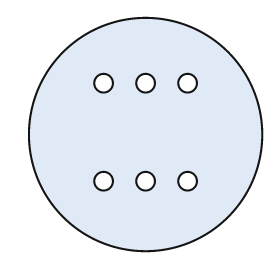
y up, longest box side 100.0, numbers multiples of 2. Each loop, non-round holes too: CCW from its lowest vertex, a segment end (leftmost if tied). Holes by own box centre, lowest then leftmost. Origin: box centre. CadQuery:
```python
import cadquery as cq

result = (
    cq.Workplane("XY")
    .moveTo(0.0, 0.0)
    .circle(50.0)
    .moveTo(-18.0, -20.0)
    .circle(4.0)
    .moveTo(0.0, -20.0)
    .circle(4.0)
    .moveTo(18.0, -20.0)
    .circle(4.0)
    .moveTo(-18.0, 22.0)
    .circle(4.0)
    .moveTo(0.0, 22.0)
    .circle(4.0)
    .moveTo(18.0, 22.0)
    .circle(4.0)
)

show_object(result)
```